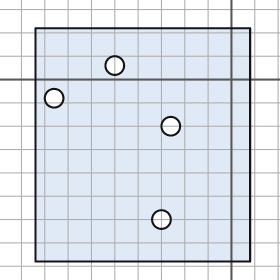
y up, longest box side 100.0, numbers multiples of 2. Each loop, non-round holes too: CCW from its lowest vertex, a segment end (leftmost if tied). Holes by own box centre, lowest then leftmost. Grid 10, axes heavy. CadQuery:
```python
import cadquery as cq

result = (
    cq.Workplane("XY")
    .moveTo(-84.0, -78.0)
    .lineTo(8.0, -78.0)
    .lineTo(8.0, 22.0)
    .lineTo(-84.0, 22.0)
    .close()
    .moveTo(-30.0, -60.0)
    .circle(4.0)
    .moveTo(-26.0, -20.0)
    .circle(4.0)
    .moveTo(-76.0, -8.0)
    .circle(4.0)
    .moveTo(-50.0, 6.0)
    .circle(4.0)
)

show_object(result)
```